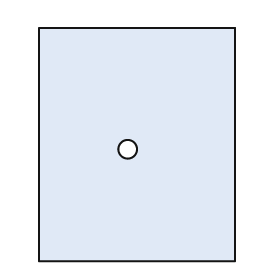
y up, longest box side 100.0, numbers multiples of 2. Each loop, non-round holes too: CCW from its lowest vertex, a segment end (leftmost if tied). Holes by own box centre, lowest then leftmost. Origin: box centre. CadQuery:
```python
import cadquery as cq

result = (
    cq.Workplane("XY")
    .moveTo(-42.0, -50.0)
    .lineTo(42.0, -50.0)
    .lineTo(42.0, 50.0)
    .lineTo(-42.0, 50.0)
    .close()
    .moveTo(-4.0, -2.0)
    .circle(4.0)
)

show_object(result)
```